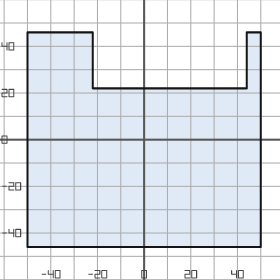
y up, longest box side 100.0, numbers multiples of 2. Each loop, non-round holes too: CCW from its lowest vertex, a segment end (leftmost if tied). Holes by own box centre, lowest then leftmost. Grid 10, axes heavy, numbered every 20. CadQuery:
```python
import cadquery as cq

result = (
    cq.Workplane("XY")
    .moveTo(-50.0, -46.0)
    .lineTo(50.0, -46.0)
    .lineTo(50.0, 46.0)
    .lineTo(44.0, 46.0)
    .lineTo(44.0, 22.0)
    .lineTo(-22.0, 22.0)
    .lineTo(-22.0, 46.0)
    .lineTo(-50.0, 46.0)
    .close()
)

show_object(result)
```